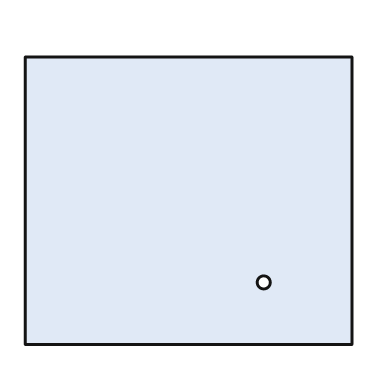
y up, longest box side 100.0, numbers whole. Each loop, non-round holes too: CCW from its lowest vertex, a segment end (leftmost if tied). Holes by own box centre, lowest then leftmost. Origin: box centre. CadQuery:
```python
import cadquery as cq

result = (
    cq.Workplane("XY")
    .moveTo(-50.0, -44.0)
    .lineTo(50.0, -44.0)
    .lineTo(50.0, 44.0)
    .lineTo(-50.0, 44.0)
    .close()
    .moveTo(23.0, -25.0)
    .circle(2.0)
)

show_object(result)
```